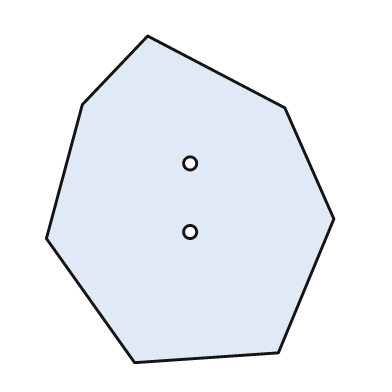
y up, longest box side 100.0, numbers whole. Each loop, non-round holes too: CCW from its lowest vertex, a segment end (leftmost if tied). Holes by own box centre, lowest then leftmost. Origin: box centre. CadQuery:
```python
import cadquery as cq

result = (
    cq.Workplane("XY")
    .moveTo(-17.0, -50.0)
    .lineTo(27.0, -47.0)
    .lineTo(44.0, -6.0)
    .lineTo(29.0, 28.0)
    .lineTo(-13.0, 50.0)
    .lineTo(-33.0, 29.0)
    .lineTo(-44.0, -12.0)
    .close()
    .moveTo(0.0, -10.0)
    .circle(2.0)
    .moveTo(0.0, 11.0)
    .circle(2.0)
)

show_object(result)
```